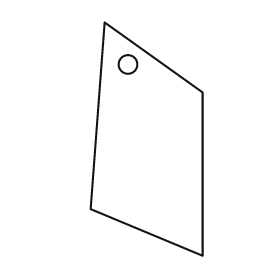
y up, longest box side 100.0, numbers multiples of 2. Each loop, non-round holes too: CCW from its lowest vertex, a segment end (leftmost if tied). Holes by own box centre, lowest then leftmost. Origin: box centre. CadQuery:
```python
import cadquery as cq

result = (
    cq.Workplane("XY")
    .moveTo(24.0, -50.0)
    .lineTo(24.0, 20.0)
    .lineTo(-18.0, 50.0)
    .lineTo(-24.0, -30.0)
    .close()
    .moveTo(-8.0, 32.0)
    .circle(4.0)
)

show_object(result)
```